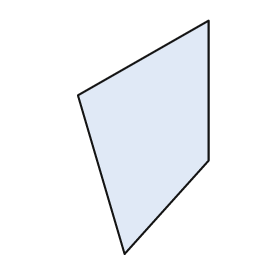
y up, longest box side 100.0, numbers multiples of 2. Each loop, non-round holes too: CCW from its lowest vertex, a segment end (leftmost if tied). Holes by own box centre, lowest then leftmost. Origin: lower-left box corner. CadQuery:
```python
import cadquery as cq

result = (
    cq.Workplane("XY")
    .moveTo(20.0, 0.0)
    .lineTo(56.0, 40.0)
    .lineTo(56.0, 100.0)
    .lineTo(0.0, 68.0)
    .close()
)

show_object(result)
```